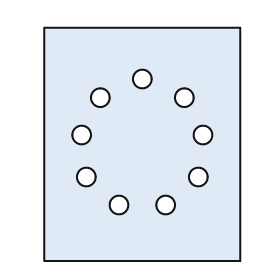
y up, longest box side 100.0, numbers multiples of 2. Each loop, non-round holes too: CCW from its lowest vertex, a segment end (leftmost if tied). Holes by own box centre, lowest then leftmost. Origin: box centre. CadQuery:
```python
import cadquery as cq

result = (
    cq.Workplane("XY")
    .moveTo(-42.0, -50.0)
    .lineTo(42.0, -50.0)
    .lineTo(42.0, 50.0)
    .lineTo(-42.0, 50.0)
    .close()
    .moveTo(-10.0, -26.0)
    .circle(4.0)
    .moveTo(10.0, -26.0)
    .circle(4.0)
    .moveTo(-24.0, -14.0)
    .circle(4.0)
    .moveTo(24.0, -14.0)
    .circle(4.0)
    .moveTo(-26.0, 4.0)
    .circle(4.0)
    .moveTo(26.0, 4.0)
    .circle(4.0)
    .moveTo(-18.0, 20.0)
    .circle(4.0)
    .moveTo(18.0, 20.0)
    .circle(4.0)
    .moveTo(0.0, 28.0)
    .circle(4.0)
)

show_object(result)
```